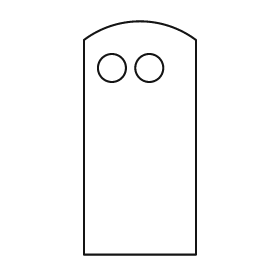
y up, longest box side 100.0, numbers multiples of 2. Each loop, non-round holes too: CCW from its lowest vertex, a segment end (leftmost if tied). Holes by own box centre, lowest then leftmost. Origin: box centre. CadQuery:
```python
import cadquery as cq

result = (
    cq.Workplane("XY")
    .moveTo(-24.0, -50.0)
    .lineTo(24.0, -50.0)
    .lineTo(24.0, 42.0)
    .threePointArc((0.0, 50.0), (-24.0, 42.0))
    .close()
    .moveTo(-12.0, 30.0)
    .circle(6.0)
    .moveTo(4.0, 30.0)
    .circle(6.0)
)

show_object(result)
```